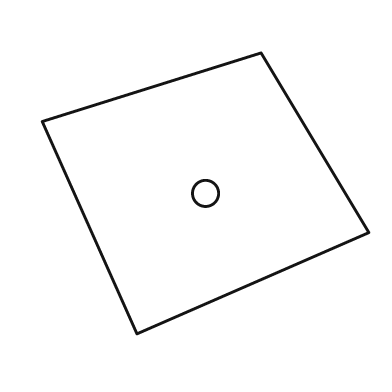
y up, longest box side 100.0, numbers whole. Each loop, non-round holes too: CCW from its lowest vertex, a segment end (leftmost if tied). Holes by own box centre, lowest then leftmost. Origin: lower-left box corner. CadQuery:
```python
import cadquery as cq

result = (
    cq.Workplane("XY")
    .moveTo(29.0, 0.0)
    .lineTo(100.0, 31.0)
    .lineTo(67.0, 86.0)
    .lineTo(0.0, 65.0)
    .close()
    .moveTo(50.0, 43.0)
    .circle(4.0)
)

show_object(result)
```